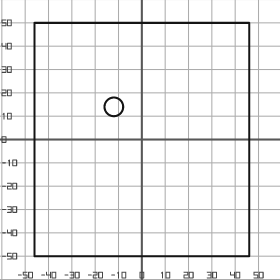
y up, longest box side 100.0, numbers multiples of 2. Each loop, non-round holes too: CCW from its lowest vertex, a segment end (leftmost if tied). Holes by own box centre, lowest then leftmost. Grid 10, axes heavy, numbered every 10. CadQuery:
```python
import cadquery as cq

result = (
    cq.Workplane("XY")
    .moveTo(-46.0, -50.0)
    .lineTo(46.0, -50.0)
    .lineTo(46.0, 50.0)
    .lineTo(-46.0, 50.0)
    .close()
    .moveTo(-12.0, 14.0)
    .circle(4.0)
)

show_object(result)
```